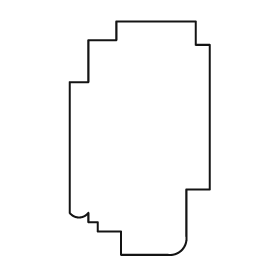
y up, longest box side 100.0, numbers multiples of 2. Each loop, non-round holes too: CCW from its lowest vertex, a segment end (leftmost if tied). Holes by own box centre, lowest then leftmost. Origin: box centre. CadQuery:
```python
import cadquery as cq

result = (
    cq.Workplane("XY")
    .moveTo(-8.0, -50.0)
    .lineTo(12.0, -50.0)
    .threePointArc((18.0, -48.0), (20.0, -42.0))
    .lineTo(20.0, -22.0)
    .lineTo(30.0, -22.0)
    .lineTo(30.0, 40.0)
    .lineTo(24.0, 40.0)
    .lineTo(24.0, 50.0)
    .lineTo(-10.0, 50.0)
    .lineTo(-10.0, 42.0)
    .lineTo(-22.0, 42.0)
    .lineTo(-22.0, 24.0)
    .lineTo(-30.0, 24.0)
    .lineTo(-30.0, -32.0)
    .threePointArc((-26.0, -34.0), (-22.0, -32.0))
    .lineTo(-22.0, -36.0)
    .lineTo(-18.0, -36.0)
    .lineTo(-18.0, -40.0)
    .lineTo(-8.0, -40.0)
    .close()
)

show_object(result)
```